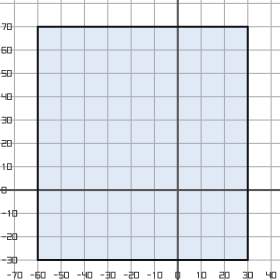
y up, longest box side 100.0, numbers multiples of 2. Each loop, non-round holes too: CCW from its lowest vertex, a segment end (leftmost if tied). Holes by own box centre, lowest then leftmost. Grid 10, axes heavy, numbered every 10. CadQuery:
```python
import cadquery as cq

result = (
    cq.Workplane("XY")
    .moveTo(-60.0, -30.0)
    .lineTo(30.0, -30.0)
    .lineTo(30.0, 70.0)
    .lineTo(-60.0, 70.0)
    .close()
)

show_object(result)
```